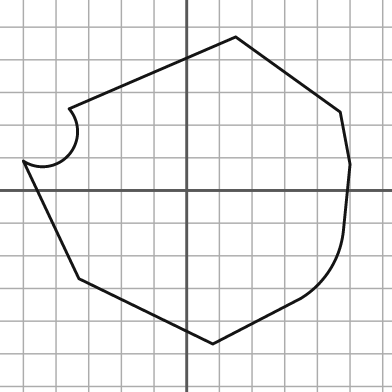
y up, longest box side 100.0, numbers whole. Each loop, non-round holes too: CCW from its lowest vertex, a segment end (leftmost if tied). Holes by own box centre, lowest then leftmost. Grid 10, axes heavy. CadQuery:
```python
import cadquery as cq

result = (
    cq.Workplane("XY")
    .moveTo(8.0, -47.0)
    .lineTo(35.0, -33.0)
    .threePointArc((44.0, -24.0), (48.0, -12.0))
    .lineTo(50.0, 8.0)
    .lineTo(47.0, 24.0)
    .lineTo(15.0, 47.0)
    .lineTo(-36.0, 25.0)
    .threePointArc((-36.0, 11.0), (-50.0, 9.0))
    .lineTo(-33.0, -27.0)
    .close()
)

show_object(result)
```